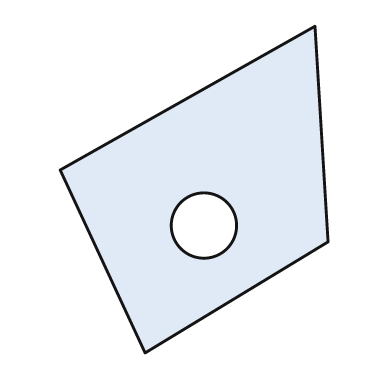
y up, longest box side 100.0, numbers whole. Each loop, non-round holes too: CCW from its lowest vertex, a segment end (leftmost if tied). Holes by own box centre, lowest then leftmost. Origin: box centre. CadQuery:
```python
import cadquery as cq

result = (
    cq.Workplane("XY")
    .moveTo(-15.0, -50.0)
    .lineTo(41.0, -16.0)
    .lineTo(37.0, 50.0)
    .lineTo(-41.0, 6.0)
    .close()
    .moveTo(3.0, -11.0)
    .circle(10.0)
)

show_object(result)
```